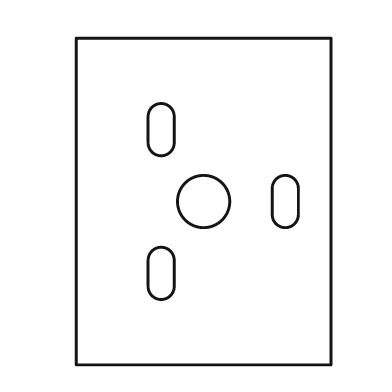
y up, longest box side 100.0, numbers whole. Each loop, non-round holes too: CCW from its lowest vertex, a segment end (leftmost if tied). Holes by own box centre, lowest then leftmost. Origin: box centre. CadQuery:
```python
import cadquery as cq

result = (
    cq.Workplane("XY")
    .moveTo(-39.0, -50.0)
    .lineTo(39.0, -50.0)
    .lineTo(39.0, 50.0)
    .lineTo(-39.0, 50.0)
    .close()
    .moveTo(-17.0, -26.0)
    .threePointArc((-13.0, -30.0), (-9.0, -26.0))
    .lineTo(-9.0, -18.0)
    .threePointArc((-13.0, -14.0), (-17.0, -18.0))
    .close()
    .moveTo(0.0, 0.0)
    .circle(8.0)
    .moveTo(21.0, -4.0)
    .threePointArc((25.0, -8.0), (29.0, -4.0))
    .lineTo(29.0, 4.0)
    .threePointArc((25.0, 8.0), (21.0, 4.0))
    .close()
    .moveTo(-17.0, 18.0)
    .threePointArc((-13.0, 14.0), (-9.0, 18.0))
    .lineTo(-9.0, 26.0)
    .threePointArc((-13.0, 30.0), (-17.0, 26.0))
    .close()
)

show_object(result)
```